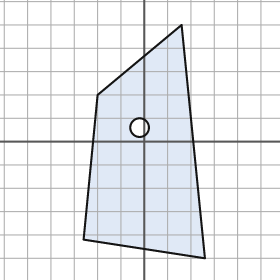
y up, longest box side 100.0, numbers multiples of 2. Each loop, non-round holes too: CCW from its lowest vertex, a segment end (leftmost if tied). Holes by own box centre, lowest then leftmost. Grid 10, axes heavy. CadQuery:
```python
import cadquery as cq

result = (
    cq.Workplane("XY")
    .moveTo(26.0, -50.0)
    .lineTo(16.0, 50.0)
    .lineTo(-20.0, 20.0)
    .lineTo(-26.0, -42.0)
    .close()
    .moveTo(-2.0, 6.0)
    .circle(4.0)
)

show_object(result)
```